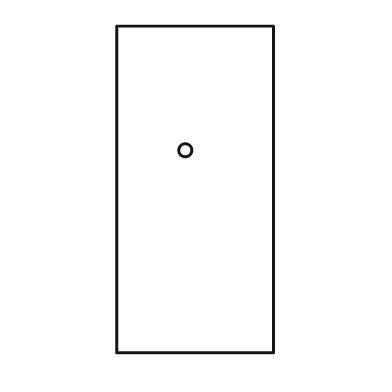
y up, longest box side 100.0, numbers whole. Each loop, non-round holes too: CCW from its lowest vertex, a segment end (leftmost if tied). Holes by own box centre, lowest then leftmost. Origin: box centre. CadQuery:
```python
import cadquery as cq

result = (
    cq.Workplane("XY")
    .moveTo(-24.0, -50.0)
    .lineTo(24.0, -50.0)
    .lineTo(24.0, 50.0)
    .lineTo(-24.0, 50.0)
    .close()
    .moveTo(-3.0, 12.0)
    .circle(2.0)
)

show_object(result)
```